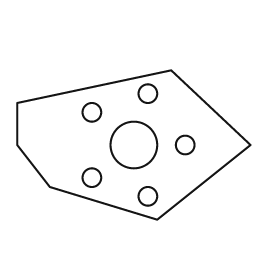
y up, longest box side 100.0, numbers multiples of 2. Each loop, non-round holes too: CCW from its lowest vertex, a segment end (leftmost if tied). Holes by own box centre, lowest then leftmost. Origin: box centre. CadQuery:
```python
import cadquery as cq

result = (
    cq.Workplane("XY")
    .moveTo(10.0, -32.0)
    .lineTo(50.0, 0.0)
    .lineTo(16.0, 32.0)
    .lineTo(-50.0, 18.0)
    .lineTo(-50.0, 0.0)
    .lineTo(-36.0, -18.0)
    .close()
    .moveTo(6.0, -22.0)
    .circle(4.0)
    .moveTo(-18.0, -14.0)
    .circle(4.0)
    .moveTo(0.0, 0.0)
    .circle(10.0)
    .moveTo(22.0, 0.0)
    .circle(4.0)
    .moveTo(-18.0, 14.0)
    .circle(4.0)
    .moveTo(6.0, 22.0)
    .circle(4.0)
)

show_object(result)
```